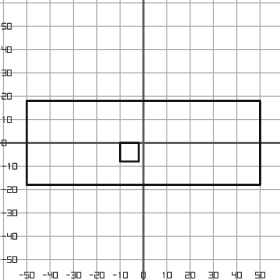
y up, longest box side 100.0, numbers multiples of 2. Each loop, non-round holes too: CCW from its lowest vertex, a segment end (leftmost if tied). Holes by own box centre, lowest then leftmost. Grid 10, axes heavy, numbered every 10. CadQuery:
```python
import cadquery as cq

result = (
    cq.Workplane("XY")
    .moveTo(-50.0, -18.0)
    .lineTo(50.0, -18.0)
    .lineTo(50.0, 18.0)
    .lineTo(-50.0, 18.0)
    .close()
    .moveTo(-10.0, -8.0)
    .lineTo(-2.0, -8.0)
    .lineTo(-2.0, 0.0)
    .lineTo(-10.0, 0.0)
    .close()
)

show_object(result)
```